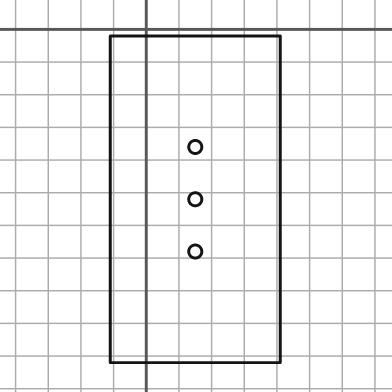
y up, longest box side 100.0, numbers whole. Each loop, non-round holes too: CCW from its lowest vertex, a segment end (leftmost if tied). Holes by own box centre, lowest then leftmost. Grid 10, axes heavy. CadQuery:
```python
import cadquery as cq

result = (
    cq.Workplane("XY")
    .moveTo(-11.0, -102.0)
    .lineTo(41.0, -102.0)
    .lineTo(41.0, -2.0)
    .lineTo(-11.0, -2.0)
    .close()
    .moveTo(15.0, -68.0)
    .circle(2.0)
    .moveTo(15.0, -52.0)
    .circle(2.0)
    .moveTo(15.0, -36.0)
    .circle(2.0)
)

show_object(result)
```